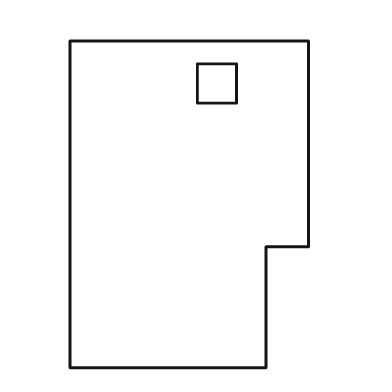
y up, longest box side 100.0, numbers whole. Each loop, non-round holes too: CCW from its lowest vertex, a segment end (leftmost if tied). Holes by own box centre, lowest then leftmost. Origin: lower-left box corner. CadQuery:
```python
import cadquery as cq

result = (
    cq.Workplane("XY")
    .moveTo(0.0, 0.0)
    .lineTo(60.0, 0.0)
    .lineTo(60.0, 37.0)
    .lineTo(73.0, 37.0)
    .lineTo(73.0, 100.0)
    .lineTo(0.0, 100.0)
    .close()
    .moveTo(39.0, 81.0)
    .lineTo(51.0, 81.0)
    .lineTo(51.0, 93.0)
    .lineTo(39.0, 93.0)
    .close()
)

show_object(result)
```